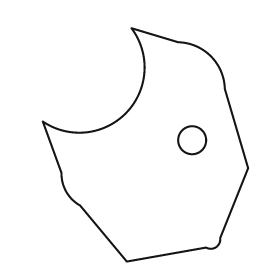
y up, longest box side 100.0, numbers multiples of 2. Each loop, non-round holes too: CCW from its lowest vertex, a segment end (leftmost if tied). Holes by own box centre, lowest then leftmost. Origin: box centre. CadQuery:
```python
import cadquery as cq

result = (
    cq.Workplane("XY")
    .moveTo(-8.0, -50.0)
    .lineTo(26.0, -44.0)
    .threePointArc((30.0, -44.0), (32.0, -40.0))
    .lineTo(44.0, -10.0)
    .lineTo(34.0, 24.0)
    .threePointArc((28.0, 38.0), (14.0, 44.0))
    .lineTo(-6.0, 50.0)
    .threePointArc((-8.0, 14.0), (-44.0, 10.0))
    .lineTo(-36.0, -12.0)
    .threePointArc((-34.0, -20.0), (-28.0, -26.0))
    .close()
    .moveTo(20.0, 2.0)
    .circle(6.0)
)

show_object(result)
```